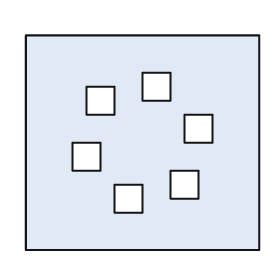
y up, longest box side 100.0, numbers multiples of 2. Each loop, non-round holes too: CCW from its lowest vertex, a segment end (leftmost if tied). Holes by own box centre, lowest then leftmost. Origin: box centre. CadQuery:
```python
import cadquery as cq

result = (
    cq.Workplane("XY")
    .moveTo(-50.0, -46.0)
    .lineTo(50.0, -46.0)
    .lineTo(50.0, 46.0)
    .lineTo(-50.0, 46.0)
    .close()
    .moveTo(-12.0, -30.0)
    .lineTo(0.0, -30.0)
    .lineTo(0.0, -18.0)
    .lineTo(-12.0, -18.0)
    .close()
    .moveTo(12.0, -24.0)
    .lineTo(24.0, -24.0)
    .lineTo(24.0, -12.0)
    .lineTo(12.0, -12.0)
    .close()
    .moveTo(-30.0, -12.0)
    .lineTo(-18.0, -12.0)
    .lineTo(-18.0, 0.0)
    .lineTo(-30.0, 0.0)
    .close()
    .moveTo(18.0, 0.0)
    .lineTo(30.0, 0.0)
    .lineTo(30.0, 12.0)
    .lineTo(18.0, 12.0)
    .close()
    .moveTo(-24.0, 12.0)
    .lineTo(-12.0, 12.0)
    .lineTo(-12.0, 24.0)
    .lineTo(-24.0, 24.0)
    .close()
    .moveTo(0.0, 18.0)
    .lineTo(12.0, 18.0)
    .lineTo(12.0, 30.0)
    .lineTo(0.0, 30.0)
    .close()
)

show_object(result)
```